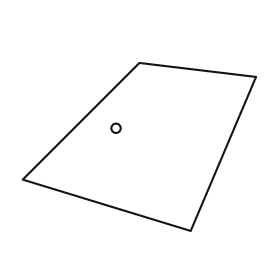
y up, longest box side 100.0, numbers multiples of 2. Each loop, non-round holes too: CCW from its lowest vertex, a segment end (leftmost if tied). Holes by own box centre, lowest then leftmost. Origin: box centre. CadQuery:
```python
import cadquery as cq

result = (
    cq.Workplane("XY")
    .moveTo(22.0, -36.0)
    .lineTo(50.0, 30.0)
    .lineTo(0.0, 36.0)
    .lineTo(-50.0, -14.0)
    .close()
    .moveTo(-10.0, 8.0)
    .circle(2.0)
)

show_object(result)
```